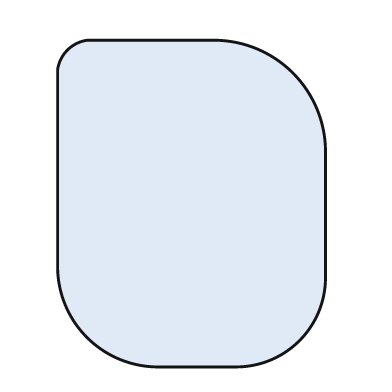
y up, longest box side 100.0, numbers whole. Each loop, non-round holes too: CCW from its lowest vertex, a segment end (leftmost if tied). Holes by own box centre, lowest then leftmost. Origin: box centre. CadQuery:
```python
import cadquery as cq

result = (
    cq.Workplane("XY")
    .moveTo(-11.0, -50.0)
    .lineTo(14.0, -50.0)
    .threePointArc((33.0, -42.0), (41.0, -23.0))
    .lineTo(41.0, 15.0)
    .threePointArc((31.0, 40.0), (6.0, 50.0))
    .lineTo(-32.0, 50.0)
    .threePointArc((-38.0, 47.0), (-41.0, 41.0))
    .lineTo(-41.0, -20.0)
    .threePointArc((-32.0, -41.0), (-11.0, -50.0))
    .close()
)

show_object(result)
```